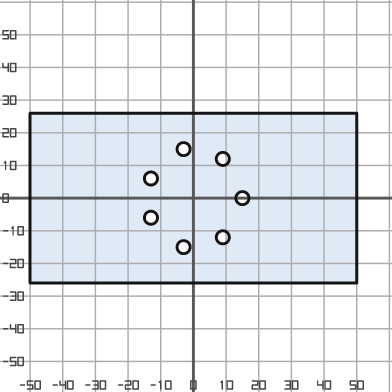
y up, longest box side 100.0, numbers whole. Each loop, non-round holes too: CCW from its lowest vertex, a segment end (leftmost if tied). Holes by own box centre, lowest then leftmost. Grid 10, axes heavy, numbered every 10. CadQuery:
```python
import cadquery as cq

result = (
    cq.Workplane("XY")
    .moveTo(-50.0, -26.0)
    .lineTo(50.0, -26.0)
    .lineTo(50.0, 26.0)
    .lineTo(-50.0, 26.0)
    .close()
    .moveTo(-3.0, -15.0)
    .circle(2.0)
    .moveTo(9.0, -12.0)
    .circle(2.0)
    .moveTo(-13.0, -6.0)
    .circle(2.0)
    .moveTo(15.0, 0.0)
    .circle(2.0)
    .moveTo(-13.0, 6.0)
    .circle(2.0)
    .moveTo(9.0, 12.0)
    .circle(2.0)
    .moveTo(-3.0, 15.0)
    .circle(2.0)
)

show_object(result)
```